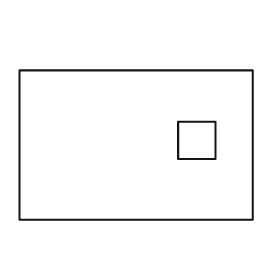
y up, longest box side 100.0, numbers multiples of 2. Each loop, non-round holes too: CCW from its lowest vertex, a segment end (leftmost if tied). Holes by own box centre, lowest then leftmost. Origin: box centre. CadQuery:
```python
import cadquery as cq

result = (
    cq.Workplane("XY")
    .moveTo(-50.0, -32.0)
    .lineTo(50.0, -32.0)
    .lineTo(50.0, 32.0)
    .lineTo(-50.0, 32.0)
    .close()
    .moveTo(18.0, -6.0)
    .lineTo(34.0, -6.0)
    .lineTo(34.0, 10.0)
    .lineTo(18.0, 10.0)
    .close()
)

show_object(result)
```